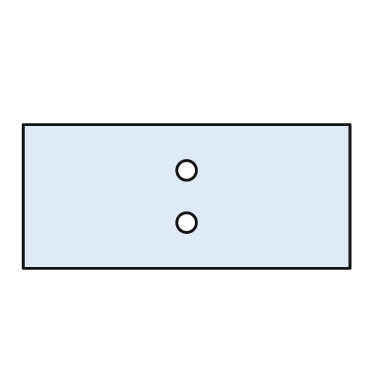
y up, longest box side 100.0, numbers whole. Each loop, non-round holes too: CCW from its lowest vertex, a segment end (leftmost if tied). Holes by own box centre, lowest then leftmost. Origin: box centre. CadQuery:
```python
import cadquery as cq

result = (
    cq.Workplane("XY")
    .moveTo(-50.0, -22.0)
    .lineTo(50.0, -22.0)
    .lineTo(50.0, 22.0)
    .lineTo(-50.0, 22.0)
    .close()
    .moveTo(0.0, -8.0)
    .circle(3.0)
    .moveTo(0.0, 8.0)
    .circle(3.0)
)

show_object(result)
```